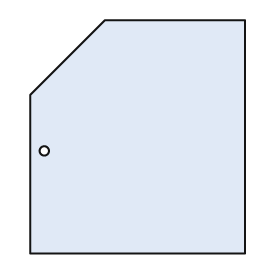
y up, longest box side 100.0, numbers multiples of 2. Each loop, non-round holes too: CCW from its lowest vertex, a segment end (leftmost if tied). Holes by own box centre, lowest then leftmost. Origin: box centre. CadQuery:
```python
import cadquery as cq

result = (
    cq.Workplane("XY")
    .moveTo(-46.0, -50.0)
    .lineTo(46.0, -50.0)
    .lineTo(46.0, 50.0)
    .lineTo(-14.0, 50.0)
    .lineTo(-46.0, 18.0)
    .close()
    .moveTo(-40.0, -6.0)
    .circle(2.0)
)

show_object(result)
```